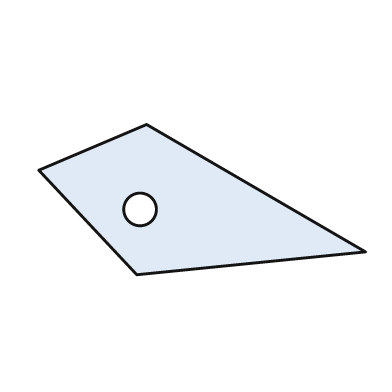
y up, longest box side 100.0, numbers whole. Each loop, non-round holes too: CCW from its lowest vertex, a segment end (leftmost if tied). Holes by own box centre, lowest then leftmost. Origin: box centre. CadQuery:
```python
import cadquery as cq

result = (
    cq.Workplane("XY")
    .moveTo(-20.0, -23.0)
    .lineTo(50.0, -16.0)
    .lineTo(-17.0, 23.0)
    .lineTo(-50.0, 9.0)
    .close()
    .moveTo(-19.0, -3.0)
    .circle(5.0)
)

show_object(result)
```